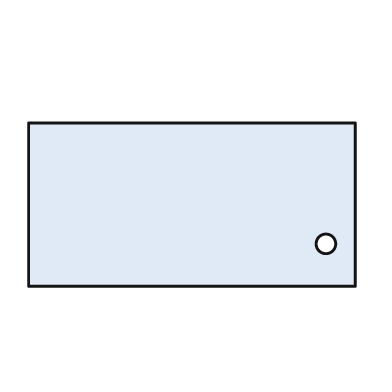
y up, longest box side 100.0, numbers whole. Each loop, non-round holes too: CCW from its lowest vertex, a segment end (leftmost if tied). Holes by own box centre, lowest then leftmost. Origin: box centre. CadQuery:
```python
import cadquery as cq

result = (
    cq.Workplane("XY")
    .moveTo(-50.0, -25.0)
    .lineTo(50.0, -25.0)
    .lineTo(50.0, 25.0)
    .lineTo(-50.0, 25.0)
    .close()
    .moveTo(41.0, -12.0)
    .circle(3.0)
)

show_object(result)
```